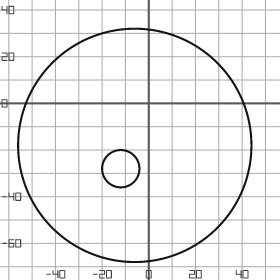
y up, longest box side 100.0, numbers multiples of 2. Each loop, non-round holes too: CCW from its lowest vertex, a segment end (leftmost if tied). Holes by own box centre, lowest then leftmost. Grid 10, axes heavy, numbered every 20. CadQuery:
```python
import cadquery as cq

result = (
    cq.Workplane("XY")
    .moveTo(-6.0, -18.0)
    .circle(50.0)
    .moveTo(-12.0, -28.0)
    .circle(8.0)
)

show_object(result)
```